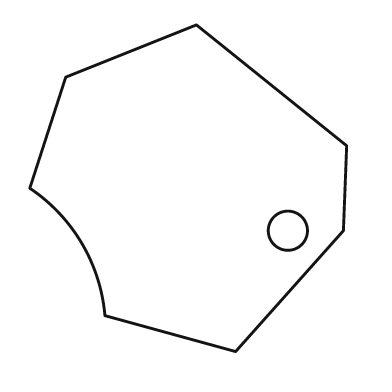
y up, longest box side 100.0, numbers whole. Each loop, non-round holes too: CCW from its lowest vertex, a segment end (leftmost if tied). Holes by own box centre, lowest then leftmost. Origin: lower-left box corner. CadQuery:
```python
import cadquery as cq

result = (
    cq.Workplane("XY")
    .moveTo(63.0, 0.0)
    .lineTo(96.0, 37.0)
    .lineTo(97.0, 63.0)
    .lineTo(51.0, 100.0)
    .lineTo(11.0, 84.0)
    .lineTo(0.0, 50.0)
    .threePointArc((16.0, 33.0), (23.0, 11.0))
    .close()
    .moveTo(79.0, 37.0)
    .circle(6.0)
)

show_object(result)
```